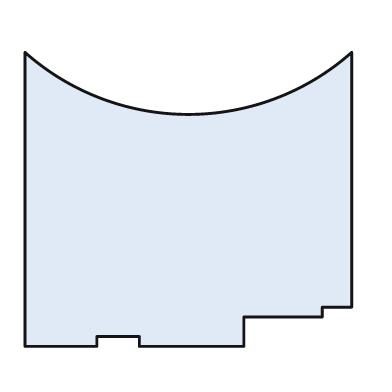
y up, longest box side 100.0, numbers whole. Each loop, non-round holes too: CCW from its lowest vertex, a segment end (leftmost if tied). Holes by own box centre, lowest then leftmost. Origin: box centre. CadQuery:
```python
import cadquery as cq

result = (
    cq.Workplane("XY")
    .moveTo(-50.0, -45.0)
    .lineTo(-28.0, -45.0)
    .lineTo(-28.0, -42.0)
    .lineTo(-15.0, -42.0)
    .lineTo(-15.0, -45.0)
    .lineTo(17.0, -45.0)
    .lineTo(17.0, -36.0)
    .lineTo(41.0, -36.0)
    .lineTo(41.0, -33.0)
    .lineTo(50.0, -33.0)
    .lineTo(50.0, 45.0)
    .threePointArc((0.0, 26.0), (-50.0, 45.0))
    .close()
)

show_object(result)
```